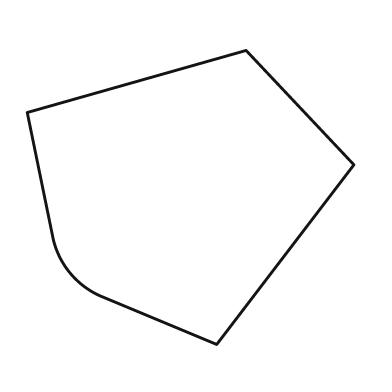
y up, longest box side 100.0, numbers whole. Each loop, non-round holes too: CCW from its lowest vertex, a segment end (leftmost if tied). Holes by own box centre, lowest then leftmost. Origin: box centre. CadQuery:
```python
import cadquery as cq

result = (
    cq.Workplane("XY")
    .moveTo(8.0, -45.0)
    .lineTo(50.0, 10.0)
    .lineTo(17.0, 45.0)
    .lineTo(-50.0, 26.0)
    .lineTo(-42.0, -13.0)
    .threePointArc((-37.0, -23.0), (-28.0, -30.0))
    .close()
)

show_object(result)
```